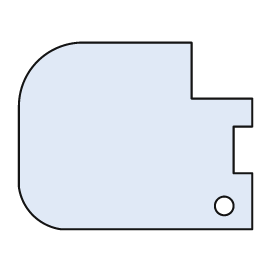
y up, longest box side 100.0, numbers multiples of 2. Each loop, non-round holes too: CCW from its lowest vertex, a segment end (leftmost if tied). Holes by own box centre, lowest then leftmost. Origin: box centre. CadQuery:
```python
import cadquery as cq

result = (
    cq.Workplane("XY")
    .moveTo(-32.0, -40.0)
    .lineTo(50.0, -40.0)
    .lineTo(50.0, -16.0)
    .lineTo(42.0, -16.0)
    .lineTo(42.0, 4.0)
    .lineTo(50.0, 4.0)
    .lineTo(50.0, 16.0)
    .lineTo(24.0, 16.0)
    .lineTo(24.0, 40.0)
    .lineTo(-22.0, 40.0)
    .threePointArc((-42.0, 32.0), (-50.0, 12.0))
    .lineTo(-50.0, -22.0)
    .threePointArc((-44.0, -34.0), (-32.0, -40.0))
    .close()
    .moveTo(38.0, -30.0)
    .circle(4.0)
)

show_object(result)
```